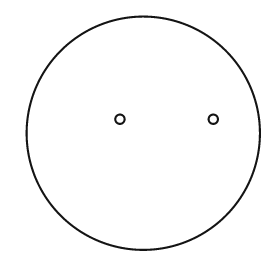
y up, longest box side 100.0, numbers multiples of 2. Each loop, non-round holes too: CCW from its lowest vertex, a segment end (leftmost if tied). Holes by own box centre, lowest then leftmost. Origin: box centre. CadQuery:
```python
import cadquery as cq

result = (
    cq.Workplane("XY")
    .moveTo(0.0, 0.0)
    .circle(50.0)
    .moveTo(-10.0, 6.0)
    .circle(2.0)
    .moveTo(30.0, 6.0)
    .circle(2.0)
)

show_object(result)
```